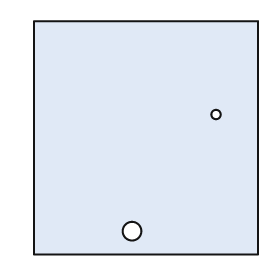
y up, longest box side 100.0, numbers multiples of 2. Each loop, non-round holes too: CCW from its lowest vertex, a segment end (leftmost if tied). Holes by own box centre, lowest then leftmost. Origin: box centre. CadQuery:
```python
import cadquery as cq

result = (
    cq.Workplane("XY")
    .moveTo(-48.0, -50.0)
    .lineTo(48.0, -50.0)
    .lineTo(48.0, 50.0)
    .lineTo(-48.0, 50.0)
    .close()
    .moveTo(-6.0, -40.0)
    .circle(4.0)
    .moveTo(30.0, 10.0)
    .circle(2.0)
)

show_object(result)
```